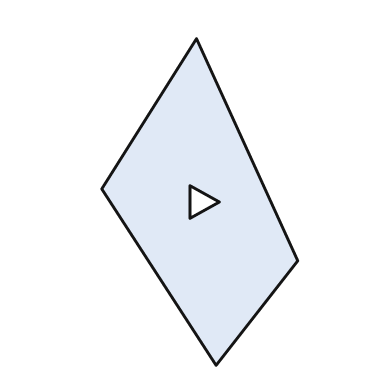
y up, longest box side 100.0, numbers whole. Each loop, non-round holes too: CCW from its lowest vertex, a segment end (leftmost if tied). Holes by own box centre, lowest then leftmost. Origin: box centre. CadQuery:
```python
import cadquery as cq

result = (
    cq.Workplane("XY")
    .moveTo(5.0, -50.0)
    .lineTo(30.0, -18.0)
    .lineTo(-1.0, 50.0)
    .lineTo(-30.0, 4.0)
    .close()
    .moveTo(-3.0, -5.0)
    .lineTo(6.0, 0.0)
    .lineTo(-3.0, 5.0)
    .close()
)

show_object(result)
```